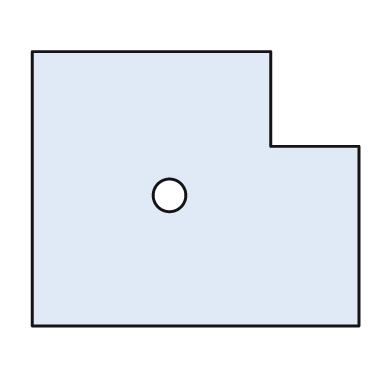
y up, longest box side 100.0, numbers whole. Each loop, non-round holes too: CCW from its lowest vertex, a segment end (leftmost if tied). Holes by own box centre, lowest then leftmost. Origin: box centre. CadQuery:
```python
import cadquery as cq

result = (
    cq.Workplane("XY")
    .moveTo(-50.0, -42.0)
    .lineTo(50.0, -42.0)
    .lineTo(50.0, 13.0)
    .lineTo(23.0, 13.0)
    .lineTo(23.0, 42.0)
    .lineTo(-50.0, 42.0)
    .close()
    .moveTo(-8.0, -2.0)
    .circle(5.0)
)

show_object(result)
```